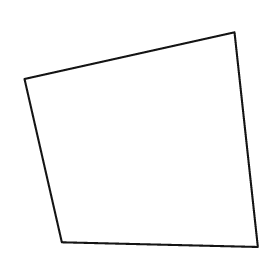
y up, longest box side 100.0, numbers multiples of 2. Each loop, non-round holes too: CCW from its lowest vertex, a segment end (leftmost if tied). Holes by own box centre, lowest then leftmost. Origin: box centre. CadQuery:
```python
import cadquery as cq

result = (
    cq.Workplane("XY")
    .moveTo(50.0, -46.0)
    .lineTo(40.0, 46.0)
    .lineTo(-50.0, 26.0)
    .lineTo(-34.0, -44.0)
    .close()
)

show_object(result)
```